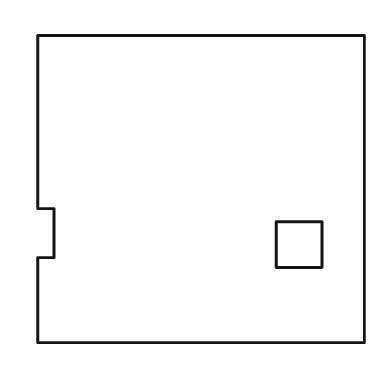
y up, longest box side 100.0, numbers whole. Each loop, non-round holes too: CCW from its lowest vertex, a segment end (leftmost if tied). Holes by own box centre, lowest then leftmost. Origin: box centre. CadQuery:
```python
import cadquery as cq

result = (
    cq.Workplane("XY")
    .moveTo(-50.0, -47.0)
    .lineTo(50.0, -47.0)
    .lineTo(50.0, 47.0)
    .lineTo(-50.0, 47.0)
    .lineTo(-50.0, -6.0)
    .lineTo(-45.0, -6.0)
    .lineTo(-45.0, -21.0)
    .lineTo(-50.0, -21.0)
    .close()
    .moveTo(23.0, -24.0)
    .lineTo(37.0, -24.0)
    .lineTo(37.0, -10.0)
    .lineTo(23.0, -10.0)
    .close()
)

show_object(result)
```